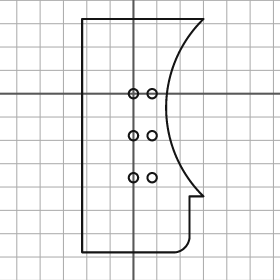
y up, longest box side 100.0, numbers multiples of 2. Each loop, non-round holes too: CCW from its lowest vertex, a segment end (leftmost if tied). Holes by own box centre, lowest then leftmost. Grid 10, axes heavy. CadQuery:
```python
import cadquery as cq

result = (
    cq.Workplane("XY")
    .moveTo(-22.0, -68.0)
    .lineTo(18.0, -68.0)
    .threePointArc((22.0, -66.0), (24.0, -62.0))
    .lineTo(24.0, -44.0)
    .lineTo(30.0, -44.0)
    .threePointArc((14.0, -6.0), (30.0, 32.0))
    .lineTo(-22.0, 32.0)
    .close()
    .moveTo(0.0, -36.0)
    .circle(2.0)
    .moveTo(8.0, -36.0)
    .circle(2.0)
    .moveTo(0.0, -18.0)
    .circle(2.0)
    .moveTo(8.0, -18.0)
    .circle(2.0)
    .moveTo(0.0, 0.0)
    .circle(2.0)
    .moveTo(8.0, 0.0)
    .circle(2.0)
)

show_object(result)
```